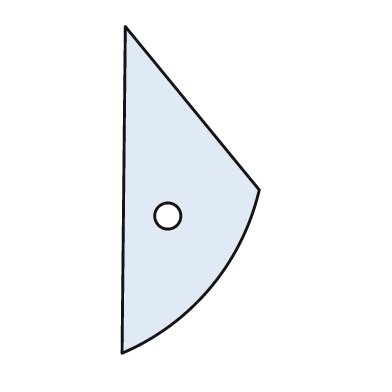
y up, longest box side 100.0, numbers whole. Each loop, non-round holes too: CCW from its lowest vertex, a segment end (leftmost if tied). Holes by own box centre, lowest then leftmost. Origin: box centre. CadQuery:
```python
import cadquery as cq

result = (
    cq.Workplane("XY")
    .moveTo(-21.0, -50.0)
    .threePointArc((6.0, -30.0), (21.0, 0.0))
    .lineTo(-20.0, 50.0)
    .close()
    .moveTo(-7.0, -8.0)
    .circle(4.0)
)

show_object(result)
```